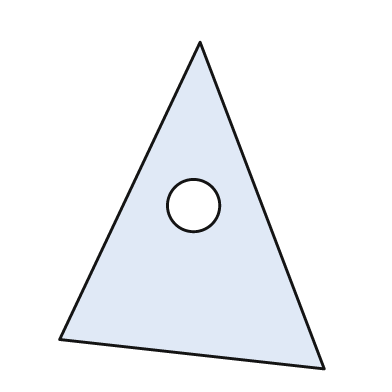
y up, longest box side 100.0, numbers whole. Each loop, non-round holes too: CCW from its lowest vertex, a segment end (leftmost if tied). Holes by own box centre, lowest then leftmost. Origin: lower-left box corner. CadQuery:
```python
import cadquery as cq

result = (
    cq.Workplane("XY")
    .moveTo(81.0, 0.0)
    .lineTo(43.0, 100.0)
    .lineTo(0.0, 9.0)
    .close()
    .moveTo(41.0, 50.0)
    .circle(8.0)
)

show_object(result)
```